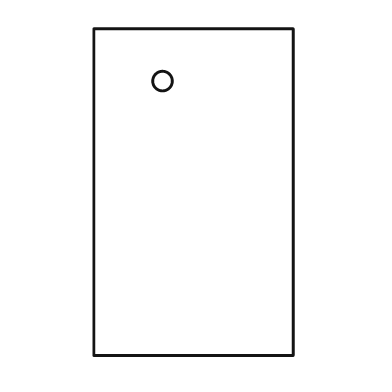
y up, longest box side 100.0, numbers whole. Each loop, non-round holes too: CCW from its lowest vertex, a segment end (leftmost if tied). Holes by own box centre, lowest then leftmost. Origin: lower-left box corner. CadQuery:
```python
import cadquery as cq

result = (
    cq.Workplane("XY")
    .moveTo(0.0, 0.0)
    .lineTo(61.0, 0.0)
    .lineTo(61.0, 100.0)
    .lineTo(0.0, 100.0)
    .close()
    .moveTo(21.0, 84.0)
    .circle(3.0)
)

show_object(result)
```